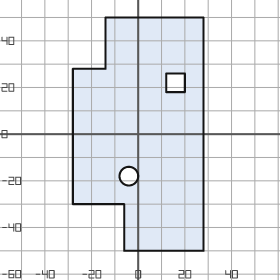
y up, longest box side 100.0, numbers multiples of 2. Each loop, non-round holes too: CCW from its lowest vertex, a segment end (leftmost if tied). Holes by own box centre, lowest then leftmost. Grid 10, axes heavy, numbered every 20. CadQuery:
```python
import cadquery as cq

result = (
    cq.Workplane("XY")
    .moveTo(-6.0, -50.0)
    .lineTo(28.0, -50.0)
    .lineTo(28.0, 50.0)
    .lineTo(-14.0, 50.0)
    .lineTo(-14.0, 28.0)
    .lineTo(-28.0, 28.0)
    .lineTo(-28.0, -30.0)
    .lineTo(-6.0, -30.0)
    .close()
    .moveTo(-4.0, -18.0)
    .circle(4.0)
    .moveTo(12.0, 18.0)
    .lineTo(20.0, 18.0)
    .lineTo(20.0, 26.0)
    .lineTo(12.0, 26.0)
    .close()
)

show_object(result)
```